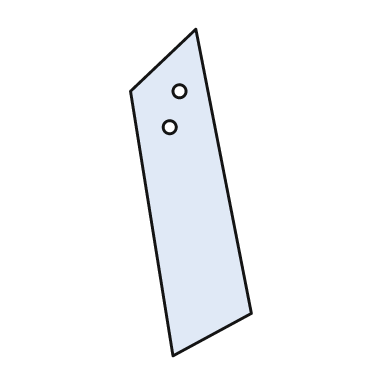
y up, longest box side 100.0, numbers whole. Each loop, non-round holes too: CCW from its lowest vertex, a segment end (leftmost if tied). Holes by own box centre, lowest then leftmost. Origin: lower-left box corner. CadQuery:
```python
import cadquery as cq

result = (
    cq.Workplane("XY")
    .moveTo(13.0, 0.0)
    .lineTo(37.0, 13.0)
    .lineTo(20.0, 100.0)
    .lineTo(0.0, 81.0)
    .close()
    .moveTo(12.0, 70.0)
    .circle(2.0)
    .moveTo(15.0, 81.0)
    .circle(2.0)
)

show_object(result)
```